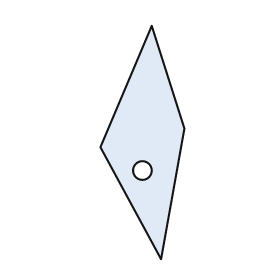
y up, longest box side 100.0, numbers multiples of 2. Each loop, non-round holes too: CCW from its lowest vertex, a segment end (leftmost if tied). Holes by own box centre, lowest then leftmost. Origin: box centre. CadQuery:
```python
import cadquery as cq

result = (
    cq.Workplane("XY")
    .moveTo(8.0, -50.0)
    .lineTo(18.0, 6.0)
    .lineTo(4.0, 50.0)
    .lineTo(-18.0, -2.0)
    .close()
    .moveTo(0.0, -12.0)
    .circle(4.0)
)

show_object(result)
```